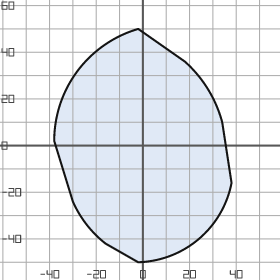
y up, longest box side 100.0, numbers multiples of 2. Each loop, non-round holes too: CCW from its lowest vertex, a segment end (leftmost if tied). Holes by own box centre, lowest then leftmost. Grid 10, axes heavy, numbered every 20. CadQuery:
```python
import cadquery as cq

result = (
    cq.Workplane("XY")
    .moveTo(-2.0, -50.0)
    .threePointArc((24.0, -40.0), (38.0, -16.0))
    .lineTo(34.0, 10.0)
    .threePointArc((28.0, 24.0), (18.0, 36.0))
    .lineTo(-2.0, 50.0)
    .threePointArc((-28.0, 32.0), (-38.0, 2.0))
    .lineTo(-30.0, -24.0)
    .threePointArc((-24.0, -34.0), (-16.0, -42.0))
    .close()
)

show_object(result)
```